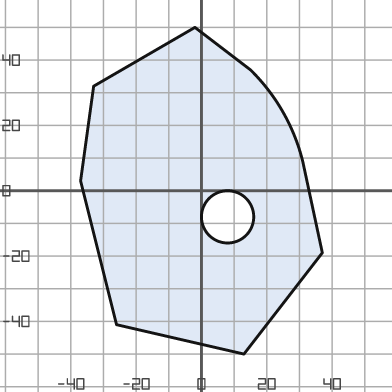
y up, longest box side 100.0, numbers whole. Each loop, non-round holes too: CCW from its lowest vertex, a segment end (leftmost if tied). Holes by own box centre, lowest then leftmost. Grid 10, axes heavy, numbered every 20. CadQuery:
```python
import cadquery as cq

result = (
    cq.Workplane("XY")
    .moveTo(13.0, -50.0)
    .lineTo(37.0, -19.0)
    .lineTo(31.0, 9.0)
    .threePointArc((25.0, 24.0), (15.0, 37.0))
    .lineTo(-2.0, 50.0)
    .lineTo(-33.0, 32.0)
    .lineTo(-37.0, 3.0)
    .lineTo(-26.0, -41.0)
    .close()
    .moveTo(8.0, -8.0)
    .circle(8.0)
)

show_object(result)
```